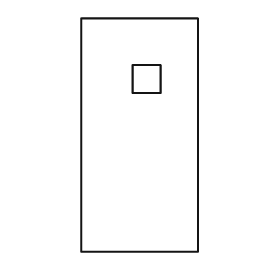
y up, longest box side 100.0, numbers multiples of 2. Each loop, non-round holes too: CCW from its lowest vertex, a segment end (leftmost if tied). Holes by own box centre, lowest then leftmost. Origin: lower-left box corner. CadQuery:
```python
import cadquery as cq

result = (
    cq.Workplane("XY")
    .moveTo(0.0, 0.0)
    .lineTo(50.0, 0.0)
    .lineTo(50.0, 100.0)
    .lineTo(0.0, 100.0)
    .close()
    .moveTo(22.0, 68.0)
    .lineTo(34.0, 68.0)
    .lineTo(34.0, 80.0)
    .lineTo(22.0, 80.0)
    .close()
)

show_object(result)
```